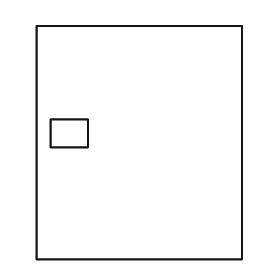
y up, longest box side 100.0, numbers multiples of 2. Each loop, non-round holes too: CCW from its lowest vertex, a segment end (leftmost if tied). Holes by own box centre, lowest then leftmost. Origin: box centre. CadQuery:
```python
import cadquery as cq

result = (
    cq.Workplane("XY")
    .moveTo(-44.0, -50.0)
    .lineTo(44.0, -50.0)
    .lineTo(44.0, 50.0)
    .lineTo(-44.0, 50.0)
    .close()
    .moveTo(-38.0, -2.0)
    .lineTo(-22.0, -2.0)
    .lineTo(-22.0, 10.0)
    .lineTo(-38.0, 10.0)
    .close()
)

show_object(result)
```